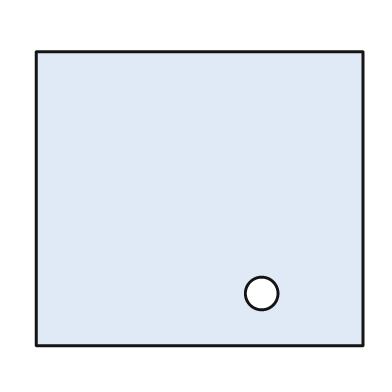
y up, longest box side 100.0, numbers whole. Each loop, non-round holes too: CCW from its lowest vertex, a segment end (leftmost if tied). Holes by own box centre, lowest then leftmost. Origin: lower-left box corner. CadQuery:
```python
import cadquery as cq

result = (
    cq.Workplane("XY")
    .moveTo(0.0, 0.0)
    .lineTo(100.0, 0.0)
    .lineTo(100.0, 90.0)
    .lineTo(0.0, 90.0)
    .close()
    .moveTo(69.0, 16.0)
    .circle(5.0)
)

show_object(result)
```